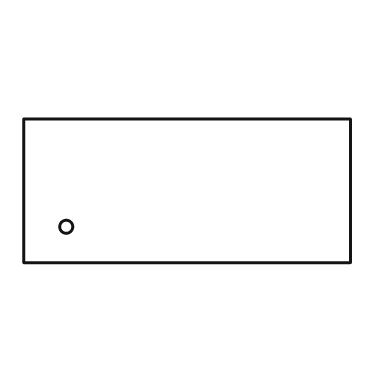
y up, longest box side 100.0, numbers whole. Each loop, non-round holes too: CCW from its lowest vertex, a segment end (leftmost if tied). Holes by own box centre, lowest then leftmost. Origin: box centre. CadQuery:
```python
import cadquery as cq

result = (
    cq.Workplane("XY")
    .moveTo(-50.0, -22.0)
    .lineTo(50.0, -22.0)
    .lineTo(50.0, 22.0)
    .lineTo(-50.0, 22.0)
    .close()
    .moveTo(-37.0, -11.0)
    .circle(2.0)
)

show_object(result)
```